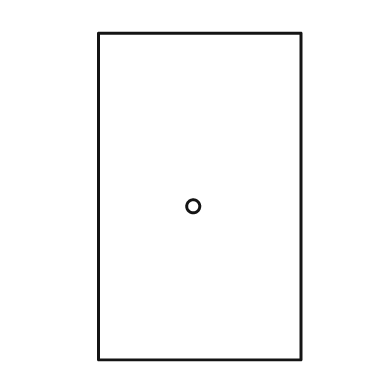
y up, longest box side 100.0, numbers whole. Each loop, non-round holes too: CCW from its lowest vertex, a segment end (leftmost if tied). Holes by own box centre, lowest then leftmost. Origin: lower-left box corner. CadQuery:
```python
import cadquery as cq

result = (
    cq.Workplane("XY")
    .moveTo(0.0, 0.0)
    .lineTo(62.0, 0.0)
    .lineTo(62.0, 100.0)
    .lineTo(0.0, 100.0)
    .close()
    .moveTo(29.0, 47.0)
    .circle(2.0)
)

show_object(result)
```